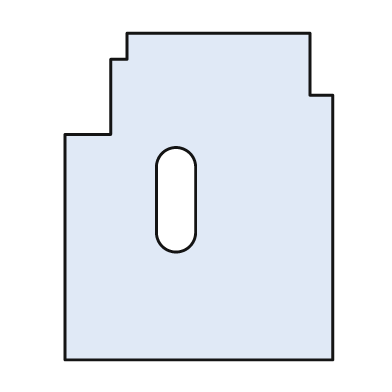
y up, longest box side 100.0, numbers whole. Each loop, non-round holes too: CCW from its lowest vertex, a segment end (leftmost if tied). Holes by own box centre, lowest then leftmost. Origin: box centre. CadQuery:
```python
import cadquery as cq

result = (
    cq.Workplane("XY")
    .moveTo(-41.0, -50.0)
    .lineTo(41.0, -50.0)
    .lineTo(41.0, 31.0)
    .lineTo(34.0, 31.0)
    .lineTo(34.0, 50.0)
    .lineTo(-22.0, 50.0)
    .lineTo(-22.0, 42.0)
    .lineTo(-27.0, 42.0)
    .lineTo(-27.0, 19.0)
    .lineTo(-41.0, 19.0)
    .close()
    .moveTo(-13.0, -11.0)
    .threePointArc((-7.0, -17.0), (-1.0, -11.0))
    .lineTo(-1.0, 9.0)
    .threePointArc((-7.0, 15.0), (-13.0, 9.0))
    .close()
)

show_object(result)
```